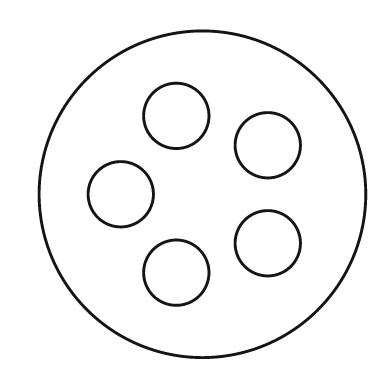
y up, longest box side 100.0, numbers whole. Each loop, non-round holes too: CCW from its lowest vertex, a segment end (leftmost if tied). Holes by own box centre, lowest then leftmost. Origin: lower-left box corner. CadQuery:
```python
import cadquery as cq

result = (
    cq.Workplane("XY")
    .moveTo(50.0, 50.0)
    .circle(50.0)
    .moveTo(42.0, 26.0)
    .circle(10.0)
    .moveTo(70.0, 35.0)
    .circle(10.0)
    .moveTo(25.0, 50.0)
    .circle(10.0)
    .moveTo(70.0, 65.0)
    .circle(10.0)
    .moveTo(42.0, 74.0)
    .circle(10.0)
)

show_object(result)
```